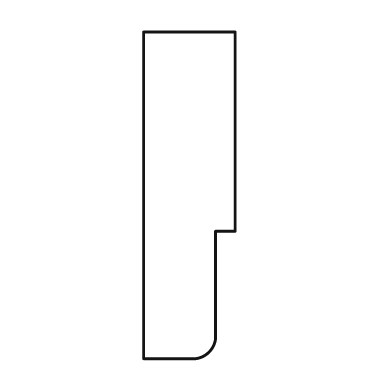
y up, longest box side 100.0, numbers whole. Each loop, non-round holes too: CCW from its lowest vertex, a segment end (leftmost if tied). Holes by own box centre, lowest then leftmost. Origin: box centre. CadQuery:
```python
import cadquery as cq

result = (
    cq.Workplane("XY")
    .moveTo(-14.0, -50.0)
    .lineTo(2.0, -50.0)
    .threePointArc((6.0, -48.0), (8.0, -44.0))
    .lineTo(8.0, -11.0)
    .lineTo(14.0, -11.0)
    .lineTo(14.0, 50.0)
    .lineTo(-14.0, 50.0)
    .close()
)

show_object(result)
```